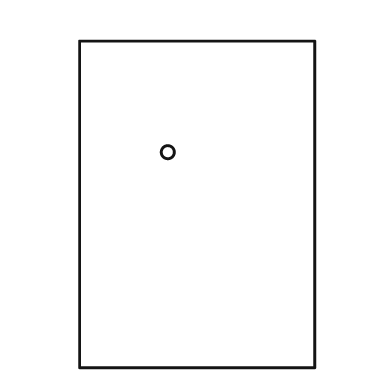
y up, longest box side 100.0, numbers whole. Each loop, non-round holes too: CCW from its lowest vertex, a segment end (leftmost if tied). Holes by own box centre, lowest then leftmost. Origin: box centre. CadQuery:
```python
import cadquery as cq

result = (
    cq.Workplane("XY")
    .moveTo(-36.0, -50.0)
    .lineTo(36.0, -50.0)
    .lineTo(36.0, 50.0)
    .lineTo(-36.0, 50.0)
    .close()
    .moveTo(-9.0, 16.0)
    .circle(2.0)
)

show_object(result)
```